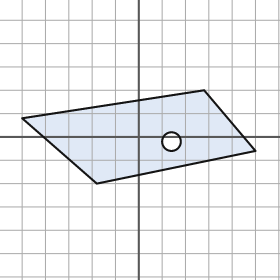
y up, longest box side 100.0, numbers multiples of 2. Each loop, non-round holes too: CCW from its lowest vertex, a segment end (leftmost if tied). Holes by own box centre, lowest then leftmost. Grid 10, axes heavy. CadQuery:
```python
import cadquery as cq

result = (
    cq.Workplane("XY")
    .moveTo(-18.0, -20.0)
    .lineTo(50.0, -6.0)
    .lineTo(28.0, 20.0)
    .lineTo(-50.0, 8.0)
    .close()
    .moveTo(14.0, -2.0)
    .circle(4.0)
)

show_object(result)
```